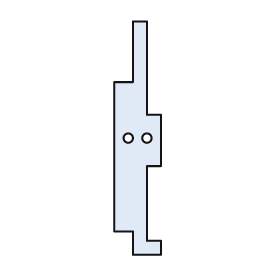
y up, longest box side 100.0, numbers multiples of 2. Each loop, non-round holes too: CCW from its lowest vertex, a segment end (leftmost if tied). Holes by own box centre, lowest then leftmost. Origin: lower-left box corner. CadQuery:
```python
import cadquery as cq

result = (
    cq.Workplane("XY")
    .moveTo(8.0, 0.0)
    .lineTo(20.0, 0.0)
    .lineTo(20.0, 6.0)
    .lineTo(14.0, 6.0)
    .lineTo(14.0, 38.0)
    .lineTo(20.0, 38.0)
    .lineTo(20.0, 60.0)
    .lineTo(14.0, 60.0)
    .lineTo(14.0, 100.0)
    .lineTo(8.0, 100.0)
    .lineTo(8.0, 74.0)
    .lineTo(0.0, 74.0)
    .lineTo(0.0, 10.0)
    .lineTo(8.0, 10.0)
    .close()
    .moveTo(6.0, 50.0)
    .circle(2.0)
    .moveTo(14.0, 50.0)
    .circle(2.0)
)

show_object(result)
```